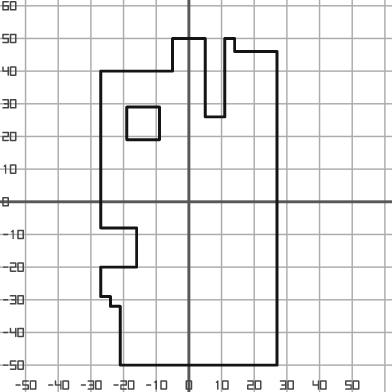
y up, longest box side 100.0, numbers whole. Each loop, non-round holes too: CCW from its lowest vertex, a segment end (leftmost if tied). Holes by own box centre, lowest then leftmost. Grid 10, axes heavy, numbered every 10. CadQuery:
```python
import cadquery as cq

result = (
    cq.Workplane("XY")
    .moveTo(-21.0, -50.0)
    .lineTo(27.0, -50.0)
    .lineTo(27.0, 46.0)
    .lineTo(14.0, 46.0)
    .lineTo(14.0, 50.0)
    .lineTo(11.0, 50.0)
    .lineTo(11.0, 26.0)
    .lineTo(5.0, 26.0)
    .lineTo(5.0, 50.0)
    .lineTo(-5.0, 50.0)
    .lineTo(-5.0, 40.0)
    .lineTo(-27.0, 40.0)
    .lineTo(-27.0, -8.0)
    .lineTo(-16.0, -8.0)
    .lineTo(-16.0, -20.0)
    .lineTo(-27.0, -20.0)
    .lineTo(-27.0, -29.0)
    .lineTo(-24.0, -29.0)
    .lineTo(-24.0, -32.0)
    .lineTo(-21.0, -32.0)
    .close()
    .moveTo(-19.0, 19.0)
    .lineTo(-9.0, 19.0)
    .lineTo(-9.0, 29.0)
    .lineTo(-19.0, 29.0)
    .close()
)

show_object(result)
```